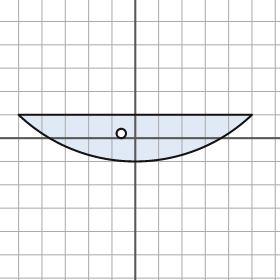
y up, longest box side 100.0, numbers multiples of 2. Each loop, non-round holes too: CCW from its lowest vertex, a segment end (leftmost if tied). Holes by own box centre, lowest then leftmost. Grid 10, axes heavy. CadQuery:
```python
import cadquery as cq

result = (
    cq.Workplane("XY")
    .moveTo(-50.0, 10.0)
    .threePointArc((0.0, -10.0), (50.0, 10.0))
    .close()
    .moveTo(-6.0, 2.0)
    .circle(2.0)
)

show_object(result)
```